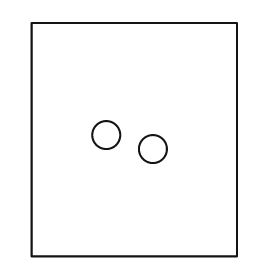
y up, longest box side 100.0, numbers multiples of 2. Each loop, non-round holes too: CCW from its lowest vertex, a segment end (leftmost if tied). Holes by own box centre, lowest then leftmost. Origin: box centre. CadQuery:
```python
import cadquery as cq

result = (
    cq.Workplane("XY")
    .moveTo(-44.0, -50.0)
    .lineTo(44.0, -50.0)
    .lineTo(44.0, 50.0)
    .lineTo(-44.0, 50.0)
    .close()
    .moveTo(8.0, -4.0)
    .circle(6.0)
    .moveTo(-12.0, 2.0)
    .circle(6.0)
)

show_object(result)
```